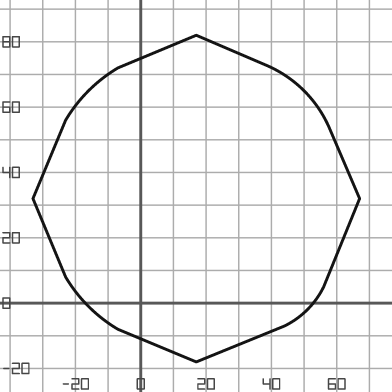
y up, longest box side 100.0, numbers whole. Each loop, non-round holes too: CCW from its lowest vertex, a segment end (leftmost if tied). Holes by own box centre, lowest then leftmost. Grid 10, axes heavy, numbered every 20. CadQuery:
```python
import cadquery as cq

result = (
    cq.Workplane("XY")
    .moveTo(17.0, -18.0)
    .lineTo(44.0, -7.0)
    .threePointArc((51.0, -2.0), (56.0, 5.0))
    .lineTo(67.0, 32.0)
    .lineTo(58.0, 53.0)
    .threePointArc((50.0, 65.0), (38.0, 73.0))
    .lineTo(17.0, 82.0)
    .lineTo(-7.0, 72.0)
    .threePointArc((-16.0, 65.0), (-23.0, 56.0))
    .lineTo(-33.0, 32.0)
    .lineTo(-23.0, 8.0)
    .threePointArc((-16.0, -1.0), (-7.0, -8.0))
    .close()
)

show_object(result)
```